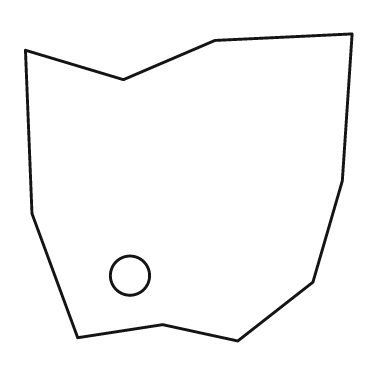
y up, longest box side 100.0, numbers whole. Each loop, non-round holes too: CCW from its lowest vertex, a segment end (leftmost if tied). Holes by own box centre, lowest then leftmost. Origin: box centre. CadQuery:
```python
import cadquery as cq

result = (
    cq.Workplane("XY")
    .moveTo(15.0, -47.0)
    .lineTo(38.0, -29.0)
    .lineTo(47.0, 2.0)
    .lineTo(50.0, 47.0)
    .lineTo(8.0, 45.0)
    .lineTo(-20.0, 33.0)
    .lineTo(-50.0, 42.0)
    .lineTo(-48.0, -8.0)
    .lineTo(-34.0, -46.0)
    .lineTo(-8.0, -42.0)
    .close()
    .moveTo(-18.0, -27.0)
    .circle(6.0)
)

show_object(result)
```